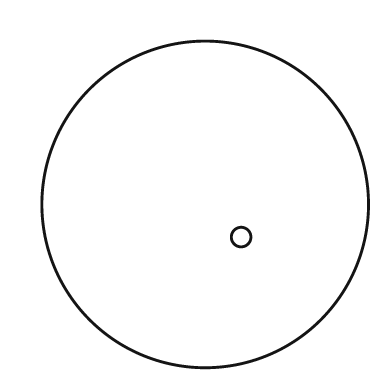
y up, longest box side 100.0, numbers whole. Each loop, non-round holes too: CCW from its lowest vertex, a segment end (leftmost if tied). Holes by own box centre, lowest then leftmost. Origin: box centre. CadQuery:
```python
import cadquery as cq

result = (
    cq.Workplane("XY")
    .moveTo(0.0, 0.0)
    .circle(50.0)
    .moveTo(11.0, -10.0)
    .circle(3.0)
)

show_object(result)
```